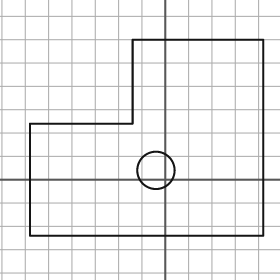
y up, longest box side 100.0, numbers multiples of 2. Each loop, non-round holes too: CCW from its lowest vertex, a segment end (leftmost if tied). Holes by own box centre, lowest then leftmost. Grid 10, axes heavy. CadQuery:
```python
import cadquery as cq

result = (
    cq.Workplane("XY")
    .moveTo(-58.0, -24.0)
    .lineTo(42.0, -24.0)
    .lineTo(42.0, 60.0)
    .lineTo(-14.0, 60.0)
    .lineTo(-14.0, 24.0)
    .lineTo(-58.0, 24.0)
    .close()
    .moveTo(-4.0, 4.0)
    .circle(8.0)
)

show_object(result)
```